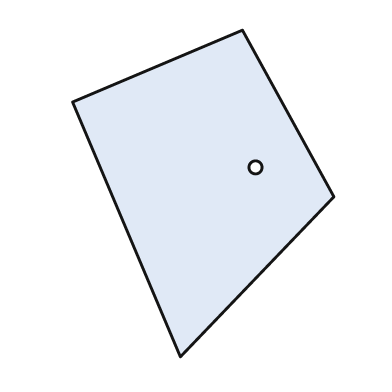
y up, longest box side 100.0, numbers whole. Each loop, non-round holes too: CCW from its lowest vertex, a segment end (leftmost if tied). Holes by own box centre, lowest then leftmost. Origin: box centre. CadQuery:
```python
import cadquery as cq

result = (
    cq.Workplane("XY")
    .moveTo(-7.0, -50.0)
    .lineTo(40.0, -1.0)
    .lineTo(12.0, 50.0)
    .lineTo(-40.0, 28.0)
    .close()
    .moveTo(16.0, 8.0)
    .circle(2.0)
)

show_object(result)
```